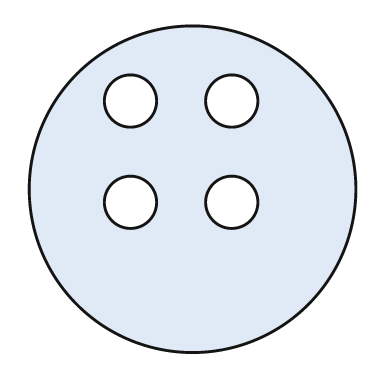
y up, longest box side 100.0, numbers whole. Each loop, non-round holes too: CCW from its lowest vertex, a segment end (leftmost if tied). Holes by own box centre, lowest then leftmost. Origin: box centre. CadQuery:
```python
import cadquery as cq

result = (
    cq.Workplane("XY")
    .moveTo(0.0, 0.0)
    .circle(50.0)
    .moveTo(-19.0, -4.0)
    .circle(8.0)
    .moveTo(12.0, -4.0)
    .circle(8.0)
    .moveTo(-19.0, 27.0)
    .circle(8.0)
    .moveTo(12.0, 27.0)
    .circle(8.0)
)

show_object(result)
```